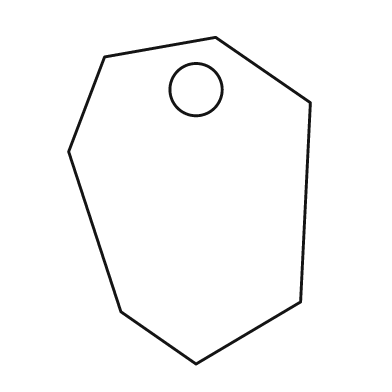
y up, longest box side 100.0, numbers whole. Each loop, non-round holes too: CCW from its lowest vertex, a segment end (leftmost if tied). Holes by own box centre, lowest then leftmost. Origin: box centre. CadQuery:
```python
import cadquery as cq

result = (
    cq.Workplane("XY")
    .moveTo(2.0, -50.0)
    .lineTo(34.0, -31.0)
    .lineTo(37.0, 30.0)
    .lineTo(8.0, 50.0)
    .lineTo(-26.0, 44.0)
    .lineTo(-37.0, 15.0)
    .lineTo(-21.0, -34.0)
    .close()
    .moveTo(2.0, 34.0)
    .circle(8.0)
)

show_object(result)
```